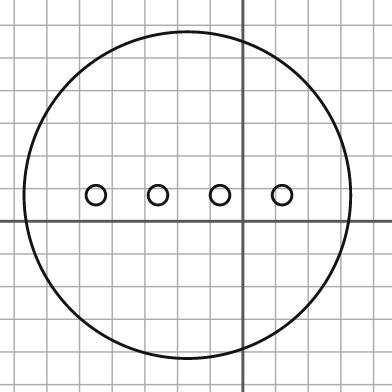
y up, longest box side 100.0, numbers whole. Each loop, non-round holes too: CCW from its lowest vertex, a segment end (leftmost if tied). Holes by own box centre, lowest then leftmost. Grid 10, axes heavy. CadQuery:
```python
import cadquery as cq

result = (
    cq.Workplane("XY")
    .moveTo(-17.0, 8.0)
    .circle(50.0)
    .moveTo(-45.0, 8.0)
    .circle(3.0)
    .moveTo(-26.0, 8.0)
    .circle(3.0)
    .moveTo(-7.0, 8.0)
    .circle(3.0)
    .moveTo(12.0, 8.0)
    .circle(3.0)
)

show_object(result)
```